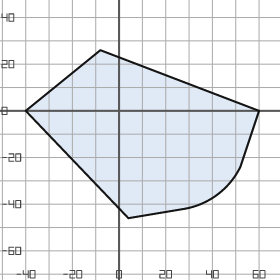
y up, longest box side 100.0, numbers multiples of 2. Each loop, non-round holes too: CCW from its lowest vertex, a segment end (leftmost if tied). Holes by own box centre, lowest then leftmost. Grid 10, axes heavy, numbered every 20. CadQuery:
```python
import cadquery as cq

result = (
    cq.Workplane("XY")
    .moveTo(4.0, -46.0)
    .lineTo(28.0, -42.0)
    .threePointArc((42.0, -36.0), (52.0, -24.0))
    .lineTo(60.0, 0.0)
    .lineTo(-8.0, 26.0)
    .lineTo(-40.0, 0.0)
    .close()
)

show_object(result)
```